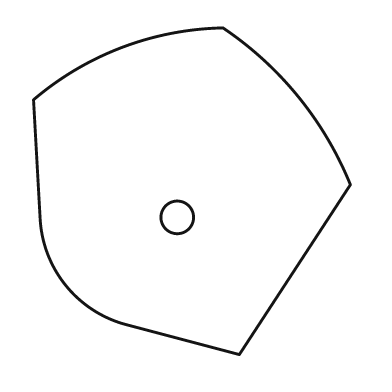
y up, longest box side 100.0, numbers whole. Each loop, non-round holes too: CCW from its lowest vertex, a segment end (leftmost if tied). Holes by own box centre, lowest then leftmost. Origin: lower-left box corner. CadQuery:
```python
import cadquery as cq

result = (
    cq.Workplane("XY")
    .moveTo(63.0, 0.0)
    .lineTo(97.0, 52.0)
    .threePointArc((81.0, 79.0), (58.0, 100.0))
    .threePointArc((27.0, 94.0), (0.0, 78.0))
    .lineTo(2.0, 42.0)
    .threePointArc((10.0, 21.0), (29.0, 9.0))
    .close()
    .moveTo(44.0, 42.0)
    .circle(5.0)
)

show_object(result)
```